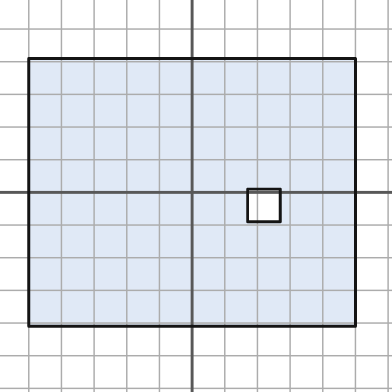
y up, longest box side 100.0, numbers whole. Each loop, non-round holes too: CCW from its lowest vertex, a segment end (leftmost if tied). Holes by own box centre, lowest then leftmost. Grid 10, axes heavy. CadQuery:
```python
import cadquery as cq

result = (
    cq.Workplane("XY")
    .moveTo(-50.0, -41.0)
    .lineTo(50.0, -41.0)
    .lineTo(50.0, 41.0)
    .lineTo(-50.0, 41.0)
    .close()
    .moveTo(17.0, -9.0)
    .lineTo(27.0, -9.0)
    .lineTo(27.0, 1.0)
    .lineTo(17.0, 1.0)
    .close()
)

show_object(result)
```